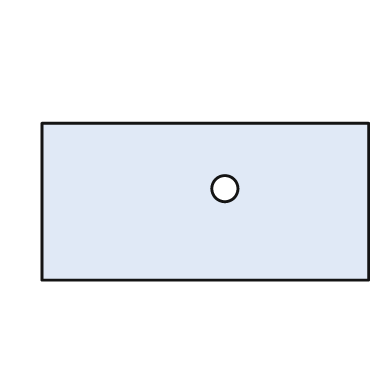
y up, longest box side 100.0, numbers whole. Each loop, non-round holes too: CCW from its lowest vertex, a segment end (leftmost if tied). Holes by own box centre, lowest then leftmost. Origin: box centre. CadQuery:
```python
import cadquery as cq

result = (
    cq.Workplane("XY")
    .moveTo(-50.0, -24.0)
    .lineTo(50.0, -24.0)
    .lineTo(50.0, 24.0)
    .lineTo(-50.0, 24.0)
    .close()
    .moveTo(6.0, 4.0)
    .circle(4.0)
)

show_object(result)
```